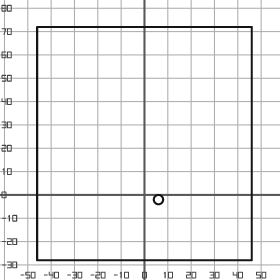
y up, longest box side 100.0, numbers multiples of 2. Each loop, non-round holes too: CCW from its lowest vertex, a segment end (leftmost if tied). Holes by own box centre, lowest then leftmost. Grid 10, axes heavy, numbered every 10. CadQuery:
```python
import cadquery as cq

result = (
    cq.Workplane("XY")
    .moveTo(-46.0, -28.0)
    .lineTo(46.0, -28.0)
    .lineTo(46.0, 72.0)
    .lineTo(-46.0, 72.0)
    .close()
    .moveTo(6.0, -2.0)
    .circle(2.0)
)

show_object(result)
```